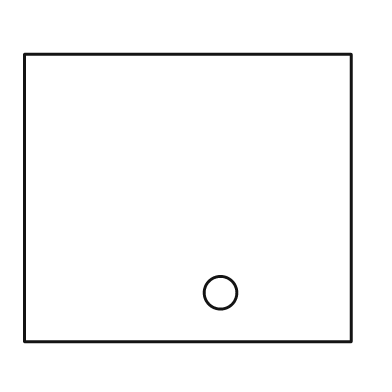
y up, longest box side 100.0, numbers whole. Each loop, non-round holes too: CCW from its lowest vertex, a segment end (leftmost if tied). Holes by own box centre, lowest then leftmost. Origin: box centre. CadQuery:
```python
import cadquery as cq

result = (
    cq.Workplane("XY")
    .moveTo(-50.0, -44.0)
    .lineTo(50.0, -44.0)
    .lineTo(50.0, 44.0)
    .lineTo(-50.0, 44.0)
    .close()
    .moveTo(10.0, -29.0)
    .circle(5.0)
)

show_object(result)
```